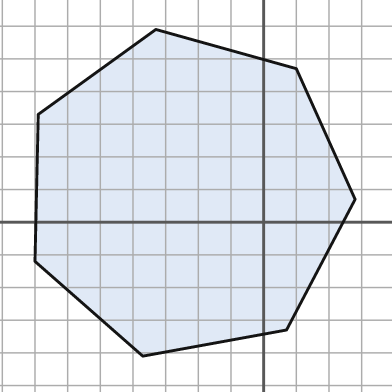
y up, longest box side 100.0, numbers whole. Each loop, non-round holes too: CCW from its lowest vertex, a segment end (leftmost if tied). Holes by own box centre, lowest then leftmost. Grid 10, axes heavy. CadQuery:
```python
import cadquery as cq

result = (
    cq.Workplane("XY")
    .moveTo(-37.0, -41.0)
    .lineTo(7.0, -33.0)
    .lineTo(28.0, 7.0)
    .lineTo(10.0, 47.0)
    .lineTo(-33.0, 59.0)
    .lineTo(-69.0, 33.0)
    .lineTo(-70.0, -12.0)
    .close()
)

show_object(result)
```